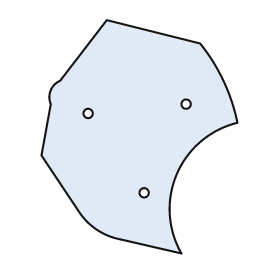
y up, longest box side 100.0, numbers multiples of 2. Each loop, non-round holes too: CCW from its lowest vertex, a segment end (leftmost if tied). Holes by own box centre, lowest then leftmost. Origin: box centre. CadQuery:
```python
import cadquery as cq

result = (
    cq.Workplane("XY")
    .moveTo(18.0, -50.0)
    .threePointArc((16.0, -16.0), (42.0, 6.0))
    .threePointArc((36.0, 24.0), (26.0, 40.0))
    .lineTo(-14.0, 50.0)
    .lineTo(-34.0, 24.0)
    .threePointArc((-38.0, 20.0), (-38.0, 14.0))
    .lineTo(-42.0, -8.0)
    .lineTo(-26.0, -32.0)
    .threePointArc((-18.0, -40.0), (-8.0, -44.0))
    .close()
    .moveTo(2.0, -24.0)
    .circle(2.0)
    .moveTo(-22.0, 10.0)
    .circle(2.0)
    .moveTo(20.0, 14.0)
    .circle(2.0)
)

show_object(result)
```